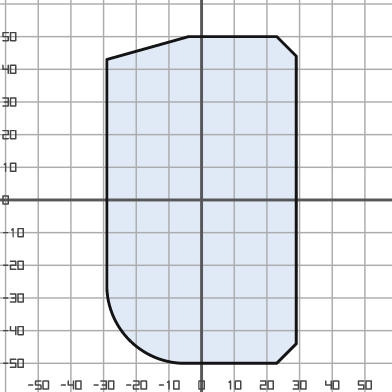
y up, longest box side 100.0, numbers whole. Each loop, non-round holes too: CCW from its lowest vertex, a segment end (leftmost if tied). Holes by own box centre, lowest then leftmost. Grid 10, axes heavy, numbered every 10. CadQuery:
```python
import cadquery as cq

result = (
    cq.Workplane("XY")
    .moveTo(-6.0, -50.0)
    .lineTo(23.0, -50.0)
    .lineTo(29.0, -44.0)
    .lineTo(29.0, 44.0)
    .lineTo(23.0, 50.0)
    .lineTo(-4.0, 50.0)
    .lineTo(-29.0, 43.0)
    .lineTo(-29.0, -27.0)
    .threePointArc((-22.0, -43.0), (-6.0, -50.0))
    .close()
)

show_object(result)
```